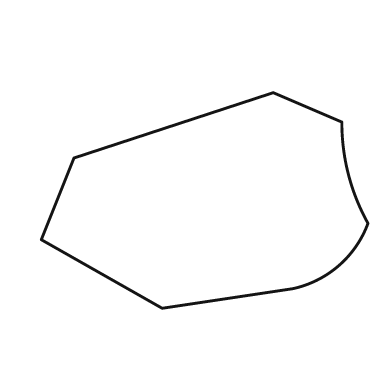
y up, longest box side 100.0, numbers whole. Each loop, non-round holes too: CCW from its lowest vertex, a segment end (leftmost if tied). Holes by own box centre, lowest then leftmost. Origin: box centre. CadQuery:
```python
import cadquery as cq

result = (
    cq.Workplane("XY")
    .moveTo(-13.0, -33.0)
    .lineTo(27.0, -27.0)
    .threePointArc((41.0, -20.0), (50.0, -7.0))
    .threePointArc((44.0, 8.0), (42.0, 24.0))
    .lineTo(21.0, 33.0)
    .lineTo(-40.0, 13.0)
    .lineTo(-50.0, -12.0)
    .close()
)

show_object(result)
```